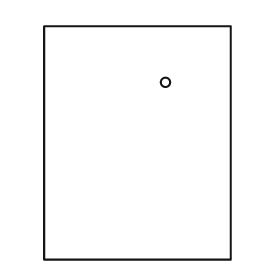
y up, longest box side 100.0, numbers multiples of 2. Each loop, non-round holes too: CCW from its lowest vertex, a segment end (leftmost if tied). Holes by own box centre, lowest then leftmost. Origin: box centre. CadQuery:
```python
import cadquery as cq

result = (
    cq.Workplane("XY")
    .moveTo(-40.0, -50.0)
    .lineTo(40.0, -50.0)
    .lineTo(40.0, 50.0)
    .lineTo(-40.0, 50.0)
    .close()
    .moveTo(12.0, 26.0)
    .circle(2.0)
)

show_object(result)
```